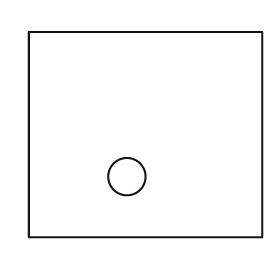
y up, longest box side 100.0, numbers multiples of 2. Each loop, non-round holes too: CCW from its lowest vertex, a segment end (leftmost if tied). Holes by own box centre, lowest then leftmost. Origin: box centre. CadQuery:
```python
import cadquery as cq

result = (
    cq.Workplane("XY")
    .moveTo(-50.0, -44.0)
    .lineTo(50.0, -44.0)
    .lineTo(50.0, 44.0)
    .lineTo(-50.0, 44.0)
    .close()
    .moveTo(-8.0, -18.0)
    .circle(8.0)
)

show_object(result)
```